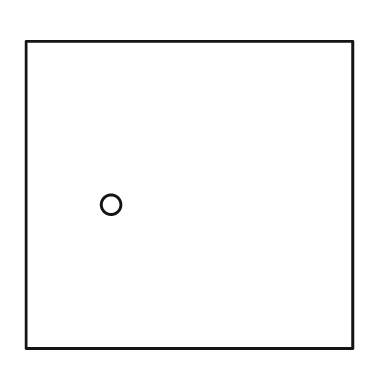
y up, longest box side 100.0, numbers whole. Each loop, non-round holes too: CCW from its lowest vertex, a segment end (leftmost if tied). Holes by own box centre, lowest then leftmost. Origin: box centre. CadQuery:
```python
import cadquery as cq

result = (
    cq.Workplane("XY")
    .moveTo(-50.0, -47.0)
    .lineTo(50.0, -47.0)
    .lineTo(50.0, 47.0)
    .lineTo(-50.0, 47.0)
    .close()
    .moveTo(-24.0, -3.0)
    .circle(3.0)
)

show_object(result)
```